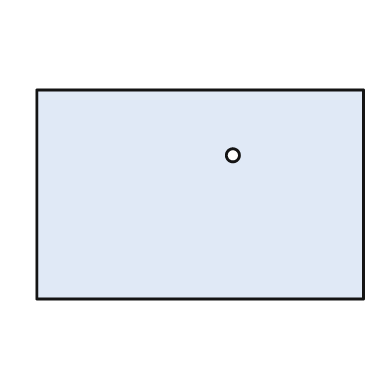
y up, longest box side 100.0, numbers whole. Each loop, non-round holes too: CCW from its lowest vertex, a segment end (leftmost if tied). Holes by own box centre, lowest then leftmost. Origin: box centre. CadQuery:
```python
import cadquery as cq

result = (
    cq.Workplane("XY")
    .moveTo(-50.0, -32.0)
    .lineTo(50.0, -32.0)
    .lineTo(50.0, 32.0)
    .lineTo(-50.0, 32.0)
    .close()
    .moveTo(10.0, 12.0)
    .circle(2.0)
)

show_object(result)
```